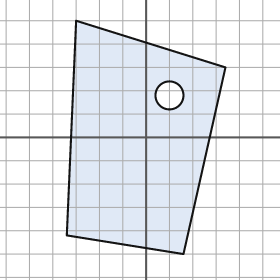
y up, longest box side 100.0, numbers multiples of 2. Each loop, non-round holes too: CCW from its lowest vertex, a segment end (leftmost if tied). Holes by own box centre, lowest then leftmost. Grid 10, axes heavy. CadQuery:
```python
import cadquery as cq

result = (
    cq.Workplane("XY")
    .moveTo(16.0, -50.0)
    .lineTo(34.0, 30.0)
    .lineTo(-30.0, 50.0)
    .lineTo(-34.0, -42.0)
    .close()
    .moveTo(10.0, 18.0)
    .circle(6.0)
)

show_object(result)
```